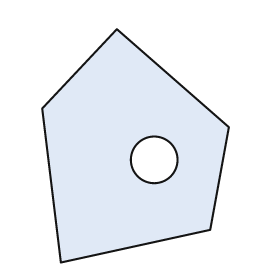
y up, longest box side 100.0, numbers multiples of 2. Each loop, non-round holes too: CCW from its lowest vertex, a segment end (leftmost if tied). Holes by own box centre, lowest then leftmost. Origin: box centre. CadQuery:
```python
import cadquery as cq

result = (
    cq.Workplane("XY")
    .moveTo(-32.0, -50.0)
    .lineTo(32.0, -36.0)
    .lineTo(40.0, 8.0)
    .lineTo(-8.0, 50.0)
    .lineTo(-40.0, 16.0)
    .close()
    .moveTo(8.0, -6.0)
    .circle(10.0)
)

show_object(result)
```